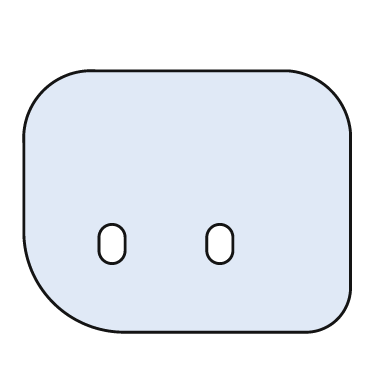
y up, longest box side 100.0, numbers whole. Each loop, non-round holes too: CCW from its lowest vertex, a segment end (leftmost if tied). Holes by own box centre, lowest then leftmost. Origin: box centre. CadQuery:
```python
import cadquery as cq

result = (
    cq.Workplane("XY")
    .moveTo(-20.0, -40.0)
    .lineTo(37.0, -40.0)
    .threePointArc((46.0, -36.0), (50.0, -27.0))
    .lineTo(50.0, 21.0)
    .threePointArc((44.0, 34.0), (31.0, 40.0))
    .lineTo(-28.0, 40.0)
    .threePointArc((-44.0, 34.0), (-50.0, 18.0))
    .lineTo(-50.0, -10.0)
    .threePointArc((-41.0, -31.0), (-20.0, -40.0))
    .close()
    .moveTo(-27.0, -15.0)
    .threePointArc((-23.0, -19.0), (-19.0, -15.0))
    .lineTo(-19.0, -11.0)
    .threePointArc((-23.0, -7.0), (-27.0, -11.0))
    .close()
    .moveTo(6.0, -15.0)
    .threePointArc((10.0, -19.0), (14.0, -15.0))
    .lineTo(14.0, -11.0)
    .threePointArc((10.0, -7.0), (6.0, -11.0))
    .close()
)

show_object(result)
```